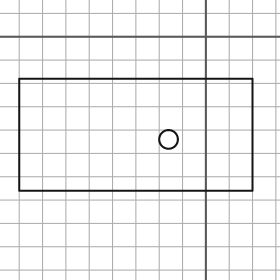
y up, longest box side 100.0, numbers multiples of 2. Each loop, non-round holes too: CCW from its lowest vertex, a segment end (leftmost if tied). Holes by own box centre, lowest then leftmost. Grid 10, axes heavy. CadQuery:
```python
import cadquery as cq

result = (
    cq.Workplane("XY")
    .moveTo(-80.0, -66.0)
    .lineTo(20.0, -66.0)
    .lineTo(20.0, -18.0)
    .lineTo(-80.0, -18.0)
    .close()
    .moveTo(-16.0, -44.0)
    .circle(4.0)
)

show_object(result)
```